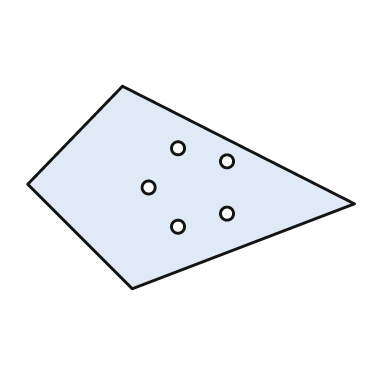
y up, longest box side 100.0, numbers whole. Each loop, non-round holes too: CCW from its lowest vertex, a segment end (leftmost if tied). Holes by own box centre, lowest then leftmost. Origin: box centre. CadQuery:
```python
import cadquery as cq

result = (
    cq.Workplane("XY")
    .moveTo(-18.0, -31.0)
    .lineTo(50.0, -5.0)
    .lineTo(-21.0, 31.0)
    .lineTo(-50.0, 1.0)
    .close()
    .moveTo(-4.0, -12.0)
    .circle(2.0)
    .moveTo(11.0, -8.0)
    .circle(2.0)
    .moveTo(-13.0, 0.0)
    .circle(2.0)
    .moveTo(11.0, 8.0)
    .circle(2.0)
    .moveTo(-4.0, 12.0)
    .circle(2.0)
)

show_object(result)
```